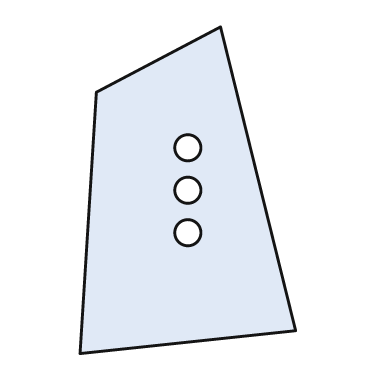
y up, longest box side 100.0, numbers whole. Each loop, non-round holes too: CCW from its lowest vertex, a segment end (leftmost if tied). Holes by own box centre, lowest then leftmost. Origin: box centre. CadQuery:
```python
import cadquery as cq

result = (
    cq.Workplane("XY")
    .moveTo(-33.0, -50.0)
    .lineTo(33.0, -43.0)
    .lineTo(10.0, 50.0)
    .lineTo(-28.0, 30.0)
    .close()
    .moveTo(0.0, -13.0)
    .circle(4.0)
    .moveTo(0.0, 0.0)
    .circle(4.0)
    .moveTo(0.0, 13.0)
    .circle(4.0)
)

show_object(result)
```